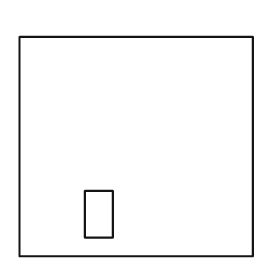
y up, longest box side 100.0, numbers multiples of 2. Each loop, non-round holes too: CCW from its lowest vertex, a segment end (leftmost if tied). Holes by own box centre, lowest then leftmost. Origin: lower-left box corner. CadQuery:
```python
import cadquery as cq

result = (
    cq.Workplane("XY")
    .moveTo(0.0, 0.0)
    .lineTo(100.0, 0.0)
    .lineTo(100.0, 94.0)
    .lineTo(0.0, 94.0)
    .close()
    .moveTo(28.0, 8.0)
    .lineTo(40.0, 8.0)
    .lineTo(40.0, 28.0)
    .lineTo(28.0, 28.0)
    .close()
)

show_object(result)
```